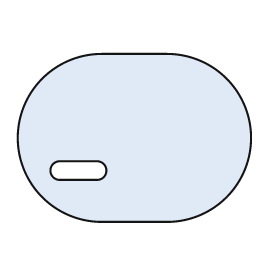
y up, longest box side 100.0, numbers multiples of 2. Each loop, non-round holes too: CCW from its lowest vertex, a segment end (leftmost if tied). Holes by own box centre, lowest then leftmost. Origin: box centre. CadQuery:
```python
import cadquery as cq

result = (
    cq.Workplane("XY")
    .moveTo(-14.0, -36.0)
    .lineTo(14.0, -36.0)
    .threePointArc((50.0, 0.0), (14.0, 36.0))
    .lineTo(-14.0, 36.0)
    .threePointArc((-50.0, 0.0), (-14.0, -36.0))
    .close()
    .moveTo(-32.0, -18.0)
    .lineTo(-16.0, -18.0)
    .threePointArc((-12.0, -14.0), (-16.0, -10.0))
    .lineTo(-32.0, -10.0)
    .threePointArc((-36.0, -14.0), (-32.0, -18.0))
    .close()
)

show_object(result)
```